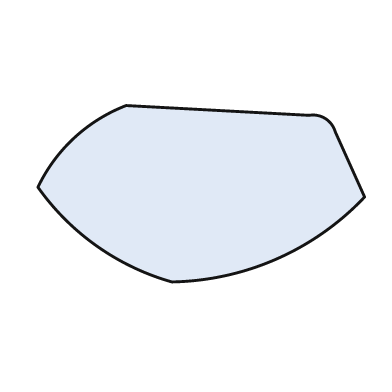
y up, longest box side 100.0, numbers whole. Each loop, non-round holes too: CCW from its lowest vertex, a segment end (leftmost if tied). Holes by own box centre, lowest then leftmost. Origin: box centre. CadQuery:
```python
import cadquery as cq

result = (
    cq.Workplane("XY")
    .moveTo(-9.0, -27.0)
    .threePointArc((23.0, -20.0), (50.0, -1.0))
    .lineTo(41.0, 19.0)
    .threePointArc((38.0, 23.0), (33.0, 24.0))
    .lineTo(-23.0, 27.0)
    .threePointArc((-39.0, 17.0), (-50.0, 2.0))
    .threePointArc((-32.0, -16.0), (-9.0, -27.0))
    .close()
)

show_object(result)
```